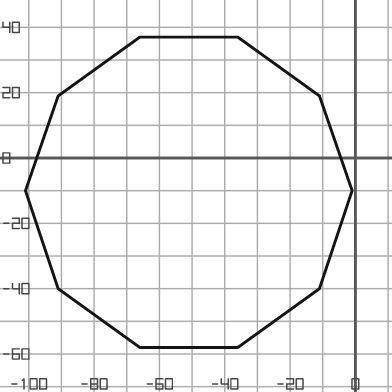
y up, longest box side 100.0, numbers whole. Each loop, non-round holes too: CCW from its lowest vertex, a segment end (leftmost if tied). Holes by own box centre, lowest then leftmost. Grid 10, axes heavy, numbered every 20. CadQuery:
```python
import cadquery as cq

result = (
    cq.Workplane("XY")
    .moveTo(-66.0, -58.0)
    .lineTo(-36.0, -58.0)
    .lineTo(-11.0, -40.0)
    .lineTo(-1.0, -10.0)
    .lineTo(-11.0, 19.0)
    .lineTo(-36.0, 37.0)
    .lineTo(-66.0, 37.0)
    .lineTo(-91.0, 19.0)
    .lineTo(-101.0, -10.0)
    .lineTo(-91.0, -40.0)
    .close()
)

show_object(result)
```